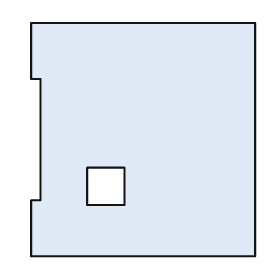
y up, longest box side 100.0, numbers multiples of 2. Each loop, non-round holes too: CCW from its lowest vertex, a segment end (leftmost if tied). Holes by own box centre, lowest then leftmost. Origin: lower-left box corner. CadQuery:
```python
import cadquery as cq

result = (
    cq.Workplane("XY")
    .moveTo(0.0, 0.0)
    .lineTo(96.0, 0.0)
    .lineTo(96.0, 100.0)
    .lineTo(0.0, 100.0)
    .lineTo(0.0, 76.0)
    .lineTo(4.0, 76.0)
    .lineTo(4.0, 24.0)
    .lineTo(0.0, 24.0)
    .close()
    .moveTo(24.0, 22.0)
    .lineTo(40.0, 22.0)
    .lineTo(40.0, 38.0)
    .lineTo(24.0, 38.0)
    .close()
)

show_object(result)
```